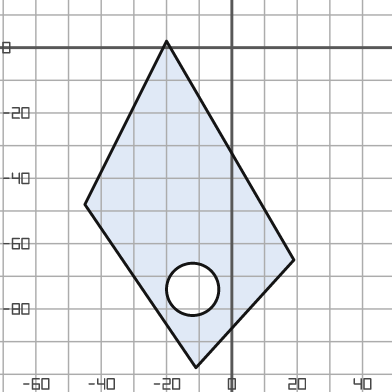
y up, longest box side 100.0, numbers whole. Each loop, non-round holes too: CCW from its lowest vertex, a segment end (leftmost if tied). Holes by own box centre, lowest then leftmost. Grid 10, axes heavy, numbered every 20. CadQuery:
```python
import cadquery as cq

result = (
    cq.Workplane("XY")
    .moveTo(-11.0, -98.0)
    .lineTo(19.0, -65.0)
    .lineTo(-20.0, 2.0)
    .lineTo(-45.0, -48.0)
    .close()
    .moveTo(-12.0, -74.0)
    .circle(8.0)
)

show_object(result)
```